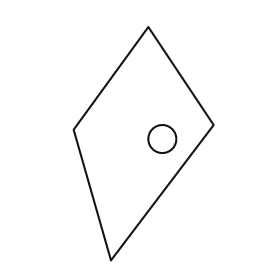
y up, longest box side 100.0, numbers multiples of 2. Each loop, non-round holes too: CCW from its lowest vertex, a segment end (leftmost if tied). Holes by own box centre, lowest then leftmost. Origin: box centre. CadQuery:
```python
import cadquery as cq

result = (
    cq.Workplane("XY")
    .moveTo(-14.0, -50.0)
    .lineTo(30.0, 8.0)
    .lineTo(2.0, 50.0)
    .lineTo(-30.0, 6.0)
    .close()
    .moveTo(8.0, 2.0)
    .circle(6.0)
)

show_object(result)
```